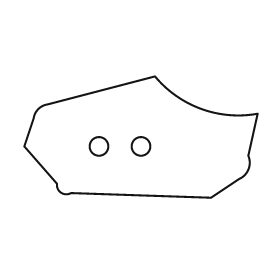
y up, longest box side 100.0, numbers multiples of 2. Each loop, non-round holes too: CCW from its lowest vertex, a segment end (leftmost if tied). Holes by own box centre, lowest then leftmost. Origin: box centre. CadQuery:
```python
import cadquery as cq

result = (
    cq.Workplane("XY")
    .moveTo(30.0, -26.0)
    .lineTo(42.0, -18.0)
    .threePointArc((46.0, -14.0), (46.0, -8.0))
    .lineTo(50.0, 10.0)
    .threePointArc((26.0, 12.0), (6.0, 26.0))
    .lineTo(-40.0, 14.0)
    .threePointArc((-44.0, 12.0), (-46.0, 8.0))
    .lineTo(-50.0, -4.0)
    .lineTo(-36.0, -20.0)
    .threePointArc((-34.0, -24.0), (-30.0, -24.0))
    .close()
    .moveTo(-18.0, -4.0)
    .circle(4.0)
    .moveTo(0.0, -4.0)
    .circle(4.0)
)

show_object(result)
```